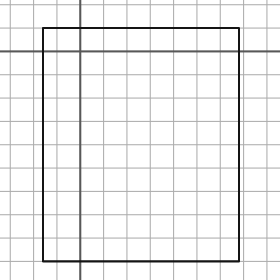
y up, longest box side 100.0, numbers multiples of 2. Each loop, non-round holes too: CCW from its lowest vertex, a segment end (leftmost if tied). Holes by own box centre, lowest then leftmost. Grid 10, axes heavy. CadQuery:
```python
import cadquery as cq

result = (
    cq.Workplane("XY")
    .moveTo(-16.0, -90.0)
    .lineTo(68.0, -90.0)
    .lineTo(68.0, 10.0)
    .lineTo(-16.0, 10.0)
    .close()
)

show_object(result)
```